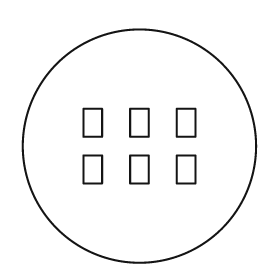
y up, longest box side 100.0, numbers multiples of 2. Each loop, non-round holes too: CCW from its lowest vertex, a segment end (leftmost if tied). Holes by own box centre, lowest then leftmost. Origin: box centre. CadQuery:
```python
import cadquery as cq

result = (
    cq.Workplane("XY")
    .moveTo(0.0, 0.0)
    .circle(50.0)
    .moveTo(-24.0, -16.0)
    .lineTo(-16.0, -16.0)
    .lineTo(-16.0, -4.0)
    .lineTo(-24.0, -4.0)
    .close()
    .moveTo(-4.0, -16.0)
    .lineTo(4.0, -16.0)
    .lineTo(4.0, -4.0)
    .lineTo(-4.0, -4.0)
    .close()
    .moveTo(16.0, -16.0)
    .lineTo(24.0, -16.0)
    .lineTo(24.0, -4.0)
    .lineTo(16.0, -4.0)
    .close()
    .moveTo(-24.0, 4.0)
    .lineTo(-16.0, 4.0)
    .lineTo(-16.0, 16.0)
    .lineTo(-24.0, 16.0)
    .close()
    .moveTo(-4.0, 4.0)
    .lineTo(4.0, 4.0)
    .lineTo(4.0, 16.0)
    .lineTo(-4.0, 16.0)
    .close()
    .moveTo(16.0, 4.0)
    .lineTo(24.0, 4.0)
    .lineTo(24.0, 16.0)
    .lineTo(16.0, 16.0)
    .close()
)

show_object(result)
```